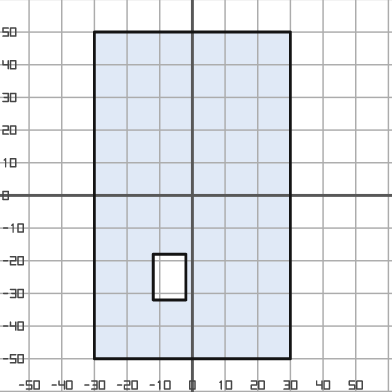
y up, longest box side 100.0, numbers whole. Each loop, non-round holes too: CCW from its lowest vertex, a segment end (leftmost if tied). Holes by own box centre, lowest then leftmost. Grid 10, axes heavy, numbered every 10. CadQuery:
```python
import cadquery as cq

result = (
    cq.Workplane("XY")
    .moveTo(-30.0, -50.0)
    .lineTo(30.0, -50.0)
    .lineTo(30.0, 50.0)
    .lineTo(-30.0, 50.0)
    .close()
    .moveTo(-12.0, -32.0)
    .lineTo(-2.0, -32.0)
    .lineTo(-2.0, -18.0)
    .lineTo(-12.0, -18.0)
    .close()
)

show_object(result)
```